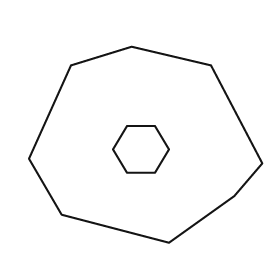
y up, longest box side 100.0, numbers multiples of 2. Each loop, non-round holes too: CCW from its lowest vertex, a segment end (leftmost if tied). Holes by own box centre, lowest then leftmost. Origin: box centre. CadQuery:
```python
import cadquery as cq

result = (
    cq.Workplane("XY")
    .moveTo(10.0, -42.0)
    .lineTo(38.0, -22.0)
    .lineTo(50.0, -8.0)
    .lineTo(28.0, 34.0)
    .lineTo(-6.0, 42.0)
    .lineTo(-32.0, 34.0)
    .lineTo(-50.0, -6.0)
    .lineTo(-36.0, -30.0)
    .close()
    .moveTo(-8.0, -12.0)
    .lineTo(4.0, -12.0)
    .lineTo(10.0, -2.0)
    .lineTo(4.0, 8.0)
    .lineTo(-8.0, 8.0)
    .lineTo(-14.0, -2.0)
    .close()
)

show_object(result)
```